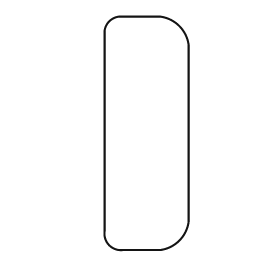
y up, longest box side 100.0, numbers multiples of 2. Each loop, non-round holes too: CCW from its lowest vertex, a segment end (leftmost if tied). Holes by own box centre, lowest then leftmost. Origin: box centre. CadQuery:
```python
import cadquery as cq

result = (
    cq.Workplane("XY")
    .moveTo(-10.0, -50.0)
    .lineTo(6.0, -50.0)
    .threePointArc((14.0, -46.0), (18.0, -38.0))
    .lineTo(18.0, 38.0)
    .threePointArc((14.0, 46.0), (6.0, 50.0))
    .lineTo(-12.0, 50.0)
    .threePointArc((-16.0, 48.0), (-18.0, 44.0))
    .lineTo(-18.0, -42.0)
    .threePointArc((-16.0, -48.0), (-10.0, -50.0))
    .close()
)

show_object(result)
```